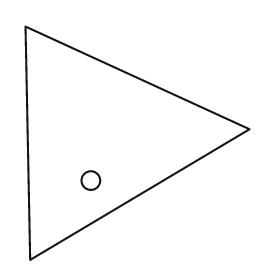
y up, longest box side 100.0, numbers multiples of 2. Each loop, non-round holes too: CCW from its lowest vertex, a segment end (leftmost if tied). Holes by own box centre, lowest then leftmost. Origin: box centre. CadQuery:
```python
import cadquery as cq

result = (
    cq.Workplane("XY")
    .moveTo(-46.0, -50.0)
    .lineTo(48.0, 6.0)
    .lineTo(-48.0, 50.0)
    .close()
    .moveTo(-20.0, -16.0)
    .circle(4.0)
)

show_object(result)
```